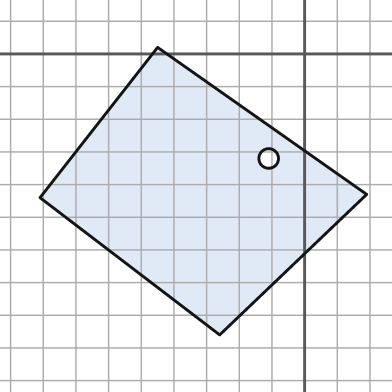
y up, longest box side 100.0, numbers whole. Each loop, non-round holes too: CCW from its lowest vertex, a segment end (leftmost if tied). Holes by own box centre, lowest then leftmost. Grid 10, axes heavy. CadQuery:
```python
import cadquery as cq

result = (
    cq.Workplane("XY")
    .moveTo(-26.0, -86.0)
    .lineTo(19.0, -43.0)
    .lineTo(-45.0, 2.0)
    .lineTo(-81.0, -44.0)
    .close()
    .moveTo(-11.0, -32.0)
    .circle(3.0)
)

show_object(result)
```